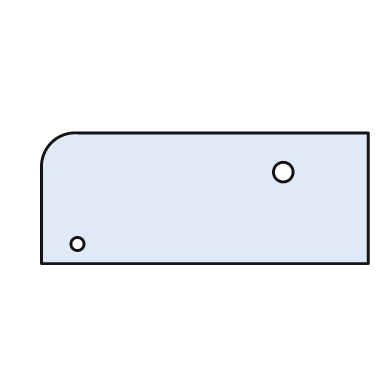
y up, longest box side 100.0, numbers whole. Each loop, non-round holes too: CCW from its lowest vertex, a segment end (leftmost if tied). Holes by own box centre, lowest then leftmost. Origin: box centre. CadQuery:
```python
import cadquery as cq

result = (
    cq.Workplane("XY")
    .moveTo(-50.0, -20.0)
    .lineTo(50.0, -20.0)
    .lineTo(50.0, 20.0)
    .lineTo(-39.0, 20.0)
    .threePointArc((-47.0, 17.0), (-50.0, 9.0))
    .close()
    .moveTo(-39.0, -14.0)
    .circle(2.0)
    .moveTo(24.0, 8.0)
    .circle(3.0)
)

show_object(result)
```